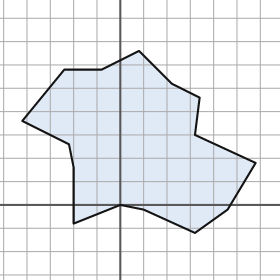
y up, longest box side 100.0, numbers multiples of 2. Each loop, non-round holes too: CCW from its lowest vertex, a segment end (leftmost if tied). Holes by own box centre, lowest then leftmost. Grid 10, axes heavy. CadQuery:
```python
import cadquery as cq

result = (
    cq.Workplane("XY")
    .moveTo(32.0, -12.0)
    .lineTo(46.0, -2.0)
    .lineTo(58.0, 18.0)
    .lineTo(32.0, 30.0)
    .lineTo(34.0, 46.0)
    .lineTo(22.0, 52.0)
    .lineTo(8.0, 66.0)
    .lineTo(-8.0, 58.0)
    .lineTo(-24.0, 58.0)
    .lineTo(-42.0, 36.0)
    .lineTo(-22.0, 26.0)
    .lineTo(-20.0, 16.0)
    .lineTo(-20.0, -8.0)
    .lineTo(0.0, 0.0)
    .lineTo(10.0, -2.0)
    .close()
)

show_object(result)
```